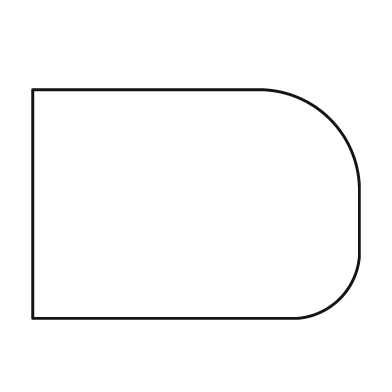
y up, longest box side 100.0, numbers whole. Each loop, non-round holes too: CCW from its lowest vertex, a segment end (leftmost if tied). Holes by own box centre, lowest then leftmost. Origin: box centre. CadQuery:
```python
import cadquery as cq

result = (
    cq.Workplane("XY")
    .moveTo(-50.0, -35.0)
    .lineTo(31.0, -35.0)
    .threePointArc((44.0, -29.0), (50.0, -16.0))
    .lineTo(50.0, 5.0)
    .threePointArc((41.0, 26.0), (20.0, 35.0))
    .lineTo(-50.0, 35.0)
    .close()
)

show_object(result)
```